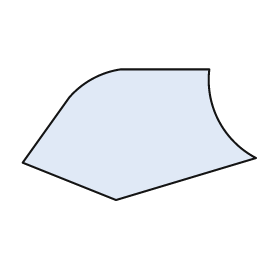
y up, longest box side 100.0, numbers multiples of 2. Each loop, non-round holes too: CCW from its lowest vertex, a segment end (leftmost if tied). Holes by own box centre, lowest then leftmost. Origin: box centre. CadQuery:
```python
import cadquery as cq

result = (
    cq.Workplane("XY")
    .moveTo(-10.0, -28.0)
    .lineTo(50.0, -10.0)
    .threePointArc((34.0, 6.0), (30.0, 28.0))
    .lineTo(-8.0, 28.0)
    .threePointArc((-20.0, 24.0), (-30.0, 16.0))
    .lineTo(-50.0, -12.0)
    .close()
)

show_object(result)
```